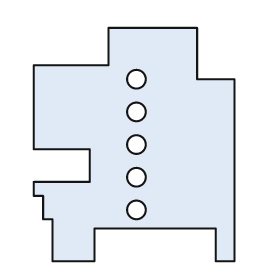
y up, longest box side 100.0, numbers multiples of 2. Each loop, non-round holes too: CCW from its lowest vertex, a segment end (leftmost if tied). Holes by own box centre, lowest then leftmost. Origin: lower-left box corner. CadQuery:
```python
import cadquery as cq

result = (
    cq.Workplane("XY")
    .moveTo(8.0, 0.0)
    .lineTo(26.0, 0.0)
    .lineTo(26.0, 14.0)
    .lineTo(78.0, 14.0)
    .lineTo(78.0, 0.0)
    .lineTo(86.0, 0.0)
    .lineTo(86.0, 78.0)
    .lineTo(70.0, 78.0)
    .lineTo(70.0, 100.0)
    .lineTo(32.0, 100.0)
    .lineTo(32.0, 84.0)
    .lineTo(0.0, 84.0)
    .lineTo(0.0, 48.0)
    .lineTo(24.0, 48.0)
    .lineTo(24.0, 34.0)
    .lineTo(0.0, 34.0)
    .lineTo(0.0, 28.0)
    .lineTo(4.0, 28.0)
    .lineTo(4.0, 18.0)
    .lineTo(8.0, 18.0)
    .close()
    .moveTo(44.0, 22.0)
    .circle(4.0)
    .moveTo(44.0, 36.0)
    .circle(4.0)
    .moveTo(44.0, 50.0)
    .circle(4.0)
    .moveTo(44.0, 64.0)
    .circle(4.0)
    .moveTo(44.0, 78.0)
    .circle(4.0)
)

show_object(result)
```